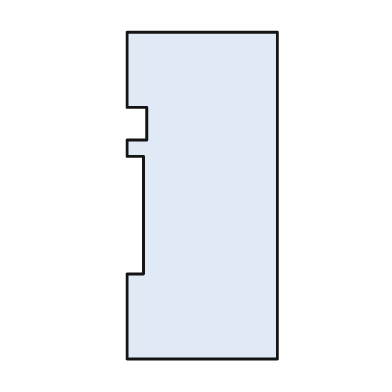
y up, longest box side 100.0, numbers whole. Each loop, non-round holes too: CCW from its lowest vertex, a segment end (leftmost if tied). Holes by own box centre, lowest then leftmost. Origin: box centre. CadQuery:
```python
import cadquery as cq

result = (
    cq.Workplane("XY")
    .moveTo(-23.0, -50.0)
    .lineTo(23.0, -50.0)
    .lineTo(23.0, 50.0)
    .lineTo(-23.0, 50.0)
    .lineTo(-23.0, 27.0)
    .lineTo(-17.0, 27.0)
    .lineTo(-17.0, 17.0)
    .lineTo(-23.0, 17.0)
    .lineTo(-23.0, 12.0)
    .lineTo(-18.0, 12.0)
    .lineTo(-18.0, -24.0)
    .lineTo(-23.0, -24.0)
    .close()
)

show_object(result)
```